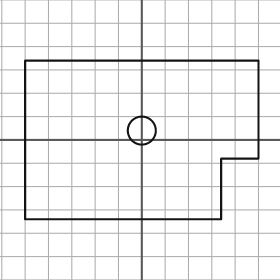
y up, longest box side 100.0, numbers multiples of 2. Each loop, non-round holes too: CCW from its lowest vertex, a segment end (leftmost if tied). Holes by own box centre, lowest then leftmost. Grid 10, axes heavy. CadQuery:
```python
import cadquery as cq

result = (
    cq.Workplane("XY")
    .moveTo(-50.0, -34.0)
    .lineTo(34.0, -34.0)
    .lineTo(34.0, -8.0)
    .lineTo(50.0, -8.0)
    .lineTo(50.0, 34.0)
    .lineTo(-50.0, 34.0)
    .close()
    .moveTo(0.0, 4.0)
    .circle(6.0)
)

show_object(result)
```